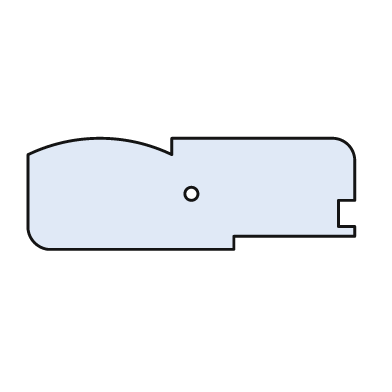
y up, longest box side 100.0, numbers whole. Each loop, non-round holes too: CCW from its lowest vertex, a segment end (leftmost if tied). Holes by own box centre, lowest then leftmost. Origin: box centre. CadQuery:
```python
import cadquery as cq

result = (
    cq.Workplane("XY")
    .moveTo(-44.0, -17.0)
    .lineTo(13.0, -17.0)
    .lineTo(13.0, -13.0)
    .lineTo(50.0, -13.0)
    .lineTo(50.0, -10.0)
    .lineTo(45.0, -10.0)
    .lineTo(45.0, -2.0)
    .lineTo(50.0, -2.0)
    .lineTo(50.0, 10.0)
    .threePointArc((48.0, 15.0), (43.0, 17.0))
    .lineTo(-6.0, 17.0)
    .lineTo(-6.0, 12.0)
    .threePointArc((-28.0, 17.0), (-50.0, 12.0))
    .lineTo(-50.0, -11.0)
    .threePointArc((-48.0, -15.0), (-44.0, -17.0))
    .close()
    .moveTo(0.0, 0.0)
    .circle(2.0)
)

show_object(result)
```